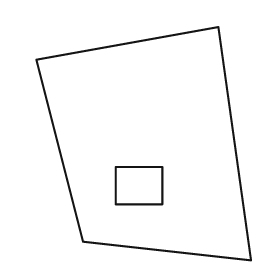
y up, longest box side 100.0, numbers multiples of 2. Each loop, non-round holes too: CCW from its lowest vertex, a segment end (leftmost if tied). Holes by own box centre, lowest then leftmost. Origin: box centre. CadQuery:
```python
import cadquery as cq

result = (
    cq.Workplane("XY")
    .moveTo(46.0, -50.0)
    .lineTo(32.0, 50.0)
    .lineTo(-46.0, 36.0)
    .lineTo(-26.0, -42.0)
    .close()
    .moveTo(-12.0, -26.0)
    .lineTo(8.0, -26.0)
    .lineTo(8.0, -10.0)
    .lineTo(-12.0, -10.0)
    .close()
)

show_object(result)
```